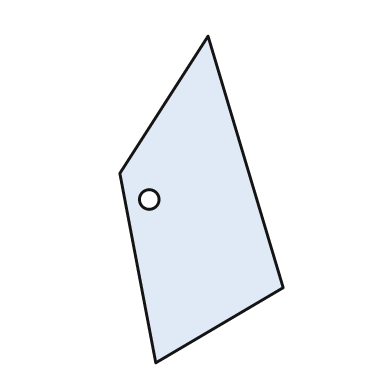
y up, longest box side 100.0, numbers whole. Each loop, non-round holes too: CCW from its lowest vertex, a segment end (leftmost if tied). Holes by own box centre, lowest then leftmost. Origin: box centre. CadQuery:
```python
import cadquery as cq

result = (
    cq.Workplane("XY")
    .moveTo(-14.0, -50.0)
    .lineTo(25.0, -27.0)
    .lineTo(2.0, 50.0)
    .lineTo(-25.0, 8.0)
    .close()
    .moveTo(-16.0, 0.0)
    .circle(3.0)
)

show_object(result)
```